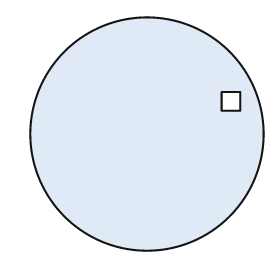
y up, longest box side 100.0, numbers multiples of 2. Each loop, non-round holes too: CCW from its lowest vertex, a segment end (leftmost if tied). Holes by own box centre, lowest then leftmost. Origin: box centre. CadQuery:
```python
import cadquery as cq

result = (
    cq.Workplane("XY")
    .moveTo(0.0, 0.0)
    .circle(50.0)
    .moveTo(32.0, 10.0)
    .lineTo(40.0, 10.0)
    .lineTo(40.0, 18.0)
    .lineTo(32.0, 18.0)
    .close()
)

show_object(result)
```